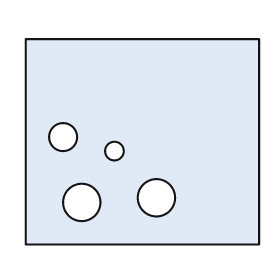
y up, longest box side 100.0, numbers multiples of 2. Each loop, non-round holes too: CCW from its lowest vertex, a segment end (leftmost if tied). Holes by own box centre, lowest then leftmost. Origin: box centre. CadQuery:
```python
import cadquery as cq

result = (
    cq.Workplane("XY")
    .moveTo(-50.0, -44.0)
    .lineTo(50.0, -44.0)
    .lineTo(50.0, 44.0)
    .lineTo(-50.0, 44.0)
    .close()
    .moveTo(-26.0, -26.0)
    .circle(8.0)
    .moveTo(6.0, -24.0)
    .circle(8.0)
    .moveTo(-12.0, -4.0)
    .circle(4.0)
    .moveTo(-34.0, 2.0)
    .circle(6.0)
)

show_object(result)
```